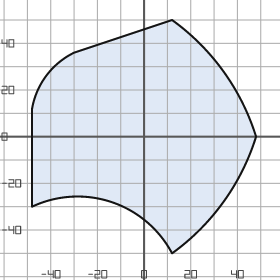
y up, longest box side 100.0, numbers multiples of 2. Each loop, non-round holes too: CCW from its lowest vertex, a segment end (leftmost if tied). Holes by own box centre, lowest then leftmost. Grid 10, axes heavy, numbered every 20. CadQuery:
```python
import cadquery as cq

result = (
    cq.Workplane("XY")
    .moveTo(12.0, -50.0)
    .threePointArc((34.0, -28.0), (48.0, 0.0))
    .threePointArc((34.0, 28.0), (12.0, 50.0))
    .lineTo(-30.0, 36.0)
    .threePointArc((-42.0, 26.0), (-48.0, 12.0))
    .lineTo(-48.0, -30.0)
    .threePointArc((-14.0, -28.0), (12.0, -50.0))
    .close()
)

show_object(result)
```